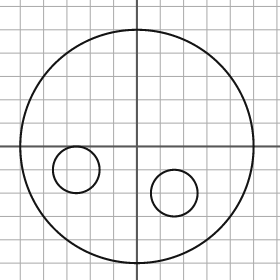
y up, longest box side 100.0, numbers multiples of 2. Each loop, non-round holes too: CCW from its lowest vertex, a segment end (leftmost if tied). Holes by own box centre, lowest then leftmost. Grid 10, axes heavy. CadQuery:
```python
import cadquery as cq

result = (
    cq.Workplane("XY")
    .moveTo(0.0, 0.0)
    .circle(50.0)
    .moveTo(16.0, -20.0)
    .circle(10.0)
    .moveTo(-26.0, -10.0)
    .circle(10.0)
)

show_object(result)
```